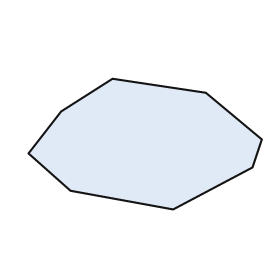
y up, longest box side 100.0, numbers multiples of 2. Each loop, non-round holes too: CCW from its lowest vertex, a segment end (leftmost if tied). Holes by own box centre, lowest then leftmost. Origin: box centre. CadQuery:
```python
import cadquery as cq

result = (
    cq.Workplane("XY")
    .moveTo(12.0, -28.0)
    .lineTo(46.0, -10.0)
    .lineTo(50.0, 2.0)
    .lineTo(26.0, 22.0)
    .lineTo(-14.0, 28.0)
    .lineTo(-36.0, 14.0)
    .lineTo(-50.0, -4.0)
    .lineTo(-32.0, -20.0)
    .close()
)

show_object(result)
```